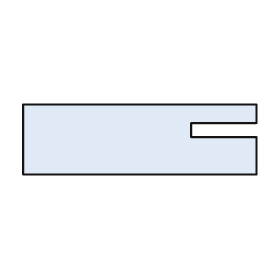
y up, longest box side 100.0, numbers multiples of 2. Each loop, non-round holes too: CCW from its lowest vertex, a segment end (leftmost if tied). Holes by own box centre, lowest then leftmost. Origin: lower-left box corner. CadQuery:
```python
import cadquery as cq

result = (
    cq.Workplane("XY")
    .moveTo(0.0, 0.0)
    .lineTo(100.0, 0.0)
    .lineTo(100.0, 16.0)
    .lineTo(72.0, 16.0)
    .lineTo(72.0, 22.0)
    .lineTo(100.0, 22.0)
    .lineTo(100.0, 30.0)
    .lineTo(0.0, 30.0)
    .close()
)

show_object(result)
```